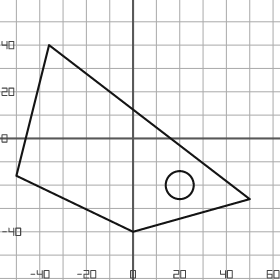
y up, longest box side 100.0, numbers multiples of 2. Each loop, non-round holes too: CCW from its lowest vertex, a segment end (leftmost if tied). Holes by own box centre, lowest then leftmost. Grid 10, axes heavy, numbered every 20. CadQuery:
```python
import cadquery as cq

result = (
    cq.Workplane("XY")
    .moveTo(0.0, -40.0)
    .lineTo(50.0, -26.0)
    .lineTo(-36.0, 40.0)
    .lineTo(-50.0, -16.0)
    .close()
    .moveTo(20.0, -20.0)
    .circle(6.0)
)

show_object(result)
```